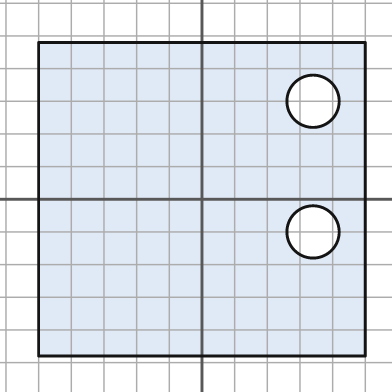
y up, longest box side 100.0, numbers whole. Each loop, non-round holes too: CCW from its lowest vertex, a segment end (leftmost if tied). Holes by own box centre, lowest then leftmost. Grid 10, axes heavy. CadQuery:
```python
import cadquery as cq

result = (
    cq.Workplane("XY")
    .moveTo(-50.0, -48.0)
    .lineTo(50.0, -48.0)
    .lineTo(50.0, 48.0)
    .lineTo(-50.0, 48.0)
    .close()
    .moveTo(34.0, -10.0)
    .circle(8.0)
    .moveTo(34.0, 30.0)
    .circle(8.0)
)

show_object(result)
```